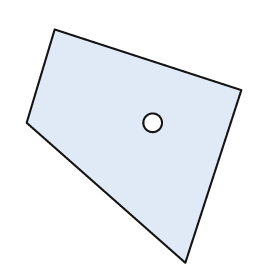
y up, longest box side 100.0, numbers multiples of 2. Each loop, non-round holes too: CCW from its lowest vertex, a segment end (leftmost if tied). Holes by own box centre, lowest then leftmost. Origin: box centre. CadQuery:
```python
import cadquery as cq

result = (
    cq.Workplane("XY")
    .moveTo(22.0, -50.0)
    .lineTo(46.0, 24.0)
    .lineTo(-34.0, 50.0)
    .lineTo(-46.0, 10.0)
    .close()
    .moveTo(8.0, 10.0)
    .circle(4.0)
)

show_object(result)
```